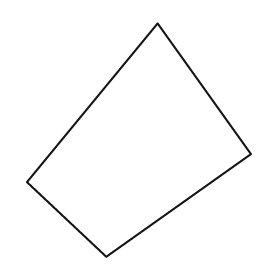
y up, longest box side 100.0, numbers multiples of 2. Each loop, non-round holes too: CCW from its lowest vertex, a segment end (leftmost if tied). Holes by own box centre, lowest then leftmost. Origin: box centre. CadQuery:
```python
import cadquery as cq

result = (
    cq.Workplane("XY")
    .moveTo(-14.0, -50.0)
    .lineTo(48.0, -6.0)
    .lineTo(8.0, 50.0)
    .lineTo(-48.0, -18.0)
    .close()
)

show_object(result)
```